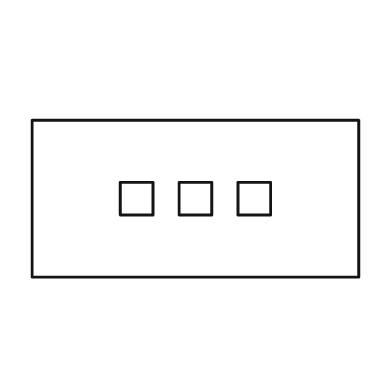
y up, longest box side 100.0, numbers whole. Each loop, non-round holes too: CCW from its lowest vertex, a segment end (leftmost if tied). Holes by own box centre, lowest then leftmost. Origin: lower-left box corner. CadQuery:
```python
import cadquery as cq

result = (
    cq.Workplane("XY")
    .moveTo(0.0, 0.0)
    .lineTo(100.0, 0.0)
    .lineTo(100.0, 48.0)
    .lineTo(0.0, 48.0)
    .close()
    .moveTo(27.0, 19.0)
    .lineTo(37.0, 19.0)
    .lineTo(37.0, 29.0)
    .lineTo(27.0, 29.0)
    .close()
    .moveTo(45.0, 19.0)
    .lineTo(55.0, 19.0)
    .lineTo(55.0, 29.0)
    .lineTo(45.0, 29.0)
    .close()
    .moveTo(63.0, 19.0)
    .lineTo(73.0, 19.0)
    .lineTo(73.0, 29.0)
    .lineTo(63.0, 29.0)
    .close()
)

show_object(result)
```